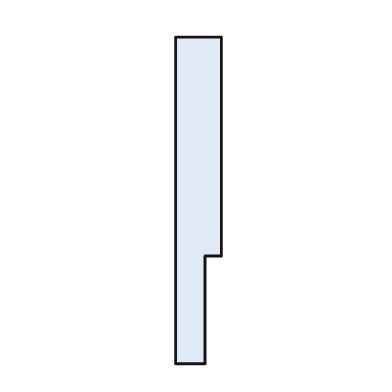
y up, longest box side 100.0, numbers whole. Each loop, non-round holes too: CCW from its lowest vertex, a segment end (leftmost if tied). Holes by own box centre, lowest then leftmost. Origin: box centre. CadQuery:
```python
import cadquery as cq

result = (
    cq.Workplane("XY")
    .moveTo(-7.0, -50.0)
    .lineTo(2.0, -50.0)
    .lineTo(2.0, -17.0)
    .lineTo(7.0, -17.0)
    .lineTo(7.0, 50.0)
    .lineTo(-7.0, 50.0)
    .close()
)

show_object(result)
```